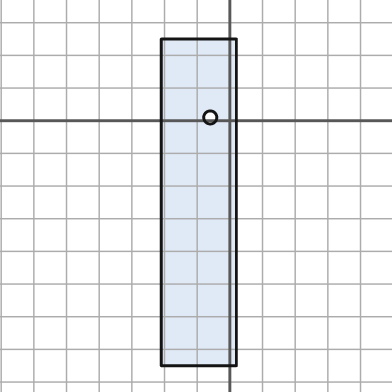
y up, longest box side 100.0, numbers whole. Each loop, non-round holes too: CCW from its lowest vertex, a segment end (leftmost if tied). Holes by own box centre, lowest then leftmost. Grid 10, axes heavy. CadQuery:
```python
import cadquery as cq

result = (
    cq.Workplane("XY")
    .moveTo(-21.0, -75.0)
    .lineTo(2.0, -75.0)
    .lineTo(2.0, 25.0)
    .lineTo(-21.0, 25.0)
    .close()
    .moveTo(-6.0, 1.0)
    .circle(2.0)
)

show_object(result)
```